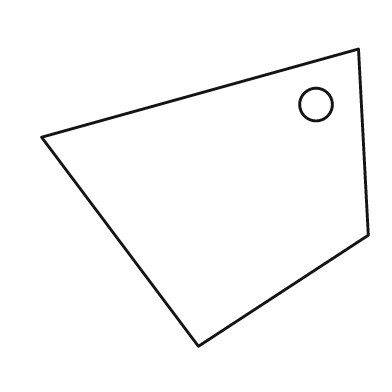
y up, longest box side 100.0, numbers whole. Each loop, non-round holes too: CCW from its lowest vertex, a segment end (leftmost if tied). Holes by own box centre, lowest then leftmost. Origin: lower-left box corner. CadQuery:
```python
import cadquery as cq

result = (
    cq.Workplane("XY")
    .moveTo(48.0, 0.0)
    .lineTo(100.0, 34.0)
    .lineTo(97.0, 91.0)
    .lineTo(0.0, 64.0)
    .close()
    .moveTo(84.0, 74.0)
    .circle(5.0)
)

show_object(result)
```